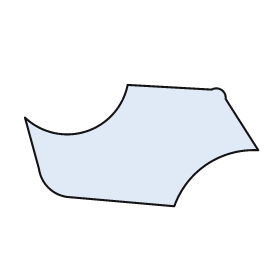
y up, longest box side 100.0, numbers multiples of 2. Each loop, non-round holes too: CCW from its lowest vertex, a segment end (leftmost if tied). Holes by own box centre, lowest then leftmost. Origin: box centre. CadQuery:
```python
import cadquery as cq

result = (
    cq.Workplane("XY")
    .moveTo(14.0, -26.0)
    .threePointArc((28.0, -8.0), (50.0, -2.0))
    .lineTo(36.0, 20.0)
    .threePointArc((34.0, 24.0), (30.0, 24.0))
    .lineTo(-6.0, 26.0)
    .threePointArc((-24.0, 6.0), (-50.0, 12.0))
    .lineTo(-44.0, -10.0)
    .threePointArc((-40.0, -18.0), (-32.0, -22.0))
    .close()
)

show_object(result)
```